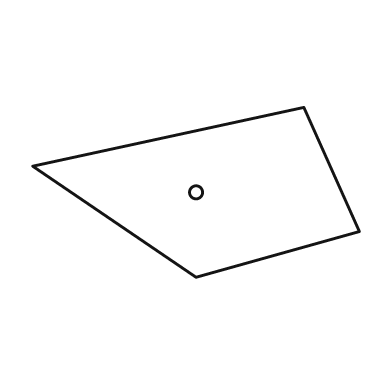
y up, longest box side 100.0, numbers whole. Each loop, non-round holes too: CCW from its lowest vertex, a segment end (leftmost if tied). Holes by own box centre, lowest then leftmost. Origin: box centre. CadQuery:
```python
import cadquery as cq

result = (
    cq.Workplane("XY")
    .moveTo(0.0, -26.0)
    .lineTo(50.0, -12.0)
    .lineTo(33.0, 26.0)
    .lineTo(-50.0, 8.0)
    .close()
    .moveTo(0.0, 0.0)
    .circle(2.0)
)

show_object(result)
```